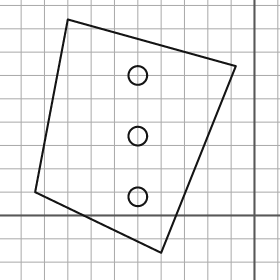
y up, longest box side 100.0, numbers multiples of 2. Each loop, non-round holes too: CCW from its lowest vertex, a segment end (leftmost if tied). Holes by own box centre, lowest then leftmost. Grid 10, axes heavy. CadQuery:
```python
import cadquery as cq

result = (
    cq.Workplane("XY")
    .moveTo(-40.0, -16.0)
    .lineTo(-8.0, 64.0)
    .lineTo(-80.0, 84.0)
    .lineTo(-94.0, 10.0)
    .close()
    .moveTo(-50.0, 8.0)
    .circle(4.0)
    .moveTo(-50.0, 34.0)
    .circle(4.0)
    .moveTo(-50.0, 60.0)
    .circle(4.0)
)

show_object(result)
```